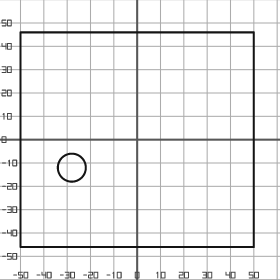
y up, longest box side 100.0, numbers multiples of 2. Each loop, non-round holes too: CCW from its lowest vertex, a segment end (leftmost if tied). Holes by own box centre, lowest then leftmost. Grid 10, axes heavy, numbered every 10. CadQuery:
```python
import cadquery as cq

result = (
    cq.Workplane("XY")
    .moveTo(-50.0, -46.0)
    .lineTo(50.0, -46.0)
    .lineTo(50.0, 46.0)
    .lineTo(-50.0, 46.0)
    .close()
    .moveTo(-28.0, -12.0)
    .circle(6.0)
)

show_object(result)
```